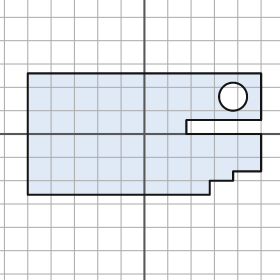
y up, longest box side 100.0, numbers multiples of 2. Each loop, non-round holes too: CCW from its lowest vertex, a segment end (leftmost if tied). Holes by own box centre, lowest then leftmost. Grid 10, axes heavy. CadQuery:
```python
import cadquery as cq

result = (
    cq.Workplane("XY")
    .moveTo(-50.0, -26.0)
    .lineTo(28.0, -26.0)
    .lineTo(28.0, -20.0)
    .lineTo(38.0, -20.0)
    .lineTo(38.0, -16.0)
    .lineTo(50.0, -16.0)
    .lineTo(50.0, 0.0)
    .lineTo(18.0, 0.0)
    .lineTo(18.0, 6.0)
    .lineTo(50.0, 6.0)
    .lineTo(50.0, 26.0)
    .lineTo(-50.0, 26.0)
    .close()
    .moveTo(38.0, 16.0)
    .circle(6.0)
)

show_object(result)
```